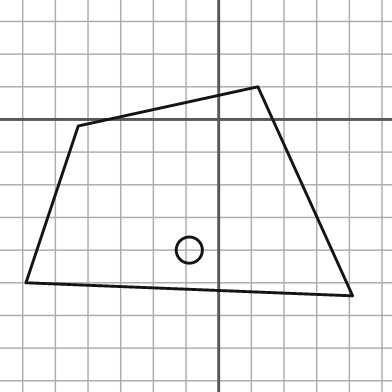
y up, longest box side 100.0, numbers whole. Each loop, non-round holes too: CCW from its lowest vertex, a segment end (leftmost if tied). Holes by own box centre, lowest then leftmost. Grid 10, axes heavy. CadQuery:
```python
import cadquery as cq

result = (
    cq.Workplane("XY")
    .moveTo(41.0, -54.0)
    .lineTo(12.0, 10.0)
    .lineTo(-43.0, -2.0)
    .lineTo(-59.0, -50.0)
    .close()
    .moveTo(-9.0, -40.0)
    .circle(4.0)
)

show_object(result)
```